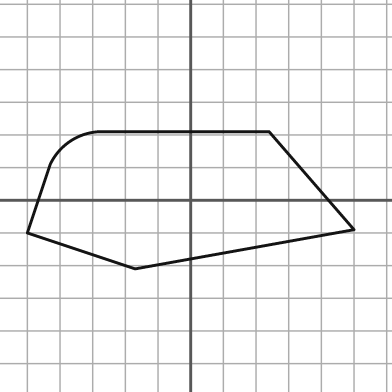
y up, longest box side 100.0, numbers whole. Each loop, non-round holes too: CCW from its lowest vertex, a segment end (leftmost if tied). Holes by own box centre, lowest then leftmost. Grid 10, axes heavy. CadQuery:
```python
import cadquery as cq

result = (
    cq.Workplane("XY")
    .moveTo(-17.0, -21.0)
    .lineTo(50.0, -9.0)
    .lineTo(24.0, 21.0)
    .lineTo(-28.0, 21.0)
    .threePointArc((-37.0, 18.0), (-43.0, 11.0))
    .lineTo(-50.0, -10.0)
    .close()
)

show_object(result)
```